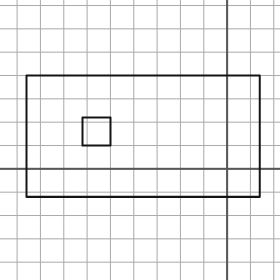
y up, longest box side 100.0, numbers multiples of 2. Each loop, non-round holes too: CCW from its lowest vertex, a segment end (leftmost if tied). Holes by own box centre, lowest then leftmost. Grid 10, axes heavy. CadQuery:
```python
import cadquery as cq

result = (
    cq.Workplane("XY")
    .moveTo(-86.0, -12.0)
    .lineTo(14.0, -12.0)
    .lineTo(14.0, 40.0)
    .lineTo(-86.0, 40.0)
    .close()
    .moveTo(-62.0, 10.0)
    .lineTo(-50.0, 10.0)
    .lineTo(-50.0, 22.0)
    .lineTo(-62.0, 22.0)
    .close()
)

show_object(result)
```